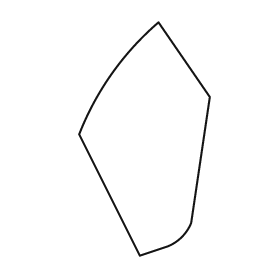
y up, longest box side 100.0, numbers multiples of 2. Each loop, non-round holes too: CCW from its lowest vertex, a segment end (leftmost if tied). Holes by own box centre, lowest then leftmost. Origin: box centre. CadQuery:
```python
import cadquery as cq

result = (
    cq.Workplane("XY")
    .moveTo(-2.0, -50.0)
    .lineTo(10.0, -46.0)
    .threePointArc((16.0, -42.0), (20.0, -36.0))
    .lineTo(28.0, 18.0)
    .lineTo(6.0, 50.0)
    .threePointArc((-14.0, 28.0), (-28.0, 2.0))
    .close()
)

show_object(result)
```